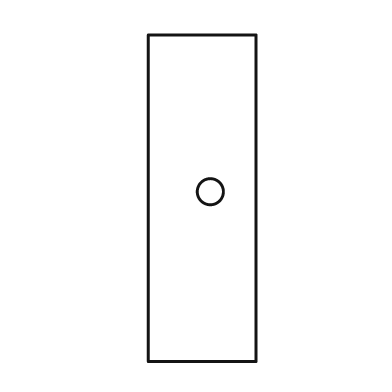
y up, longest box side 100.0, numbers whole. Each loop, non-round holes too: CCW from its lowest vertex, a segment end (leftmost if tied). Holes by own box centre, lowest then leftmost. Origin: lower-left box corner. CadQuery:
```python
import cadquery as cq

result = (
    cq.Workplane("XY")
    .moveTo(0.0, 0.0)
    .lineTo(33.0, 0.0)
    .lineTo(33.0, 100.0)
    .lineTo(0.0, 100.0)
    .close()
    .moveTo(19.0, 52.0)
    .circle(4.0)
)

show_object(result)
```